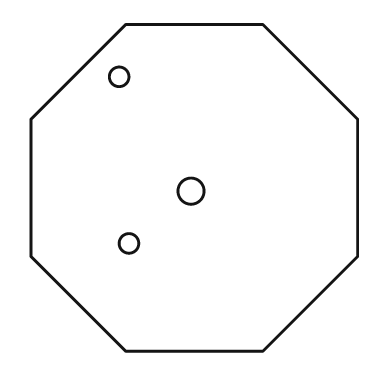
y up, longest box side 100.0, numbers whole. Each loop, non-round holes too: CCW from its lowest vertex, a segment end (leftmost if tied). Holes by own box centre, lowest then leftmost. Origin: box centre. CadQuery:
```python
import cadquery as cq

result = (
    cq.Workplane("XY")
    .moveTo(-21.0, -50.0)
    .lineTo(21.0, -50.0)
    .lineTo(50.0, -21.0)
    .lineTo(50.0, 21.0)
    .lineTo(21.0, 50.0)
    .lineTo(-21.0, 50.0)
    .lineTo(-50.0, 21.0)
    .lineTo(-50.0, -21.0)
    .close()
    .moveTo(-20.0, -17.0)
    .circle(3.0)
    .moveTo(-1.0, -1.0)
    .circle(4.0)
    .moveTo(-23.0, 34.0)
    .circle(3.0)
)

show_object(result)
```